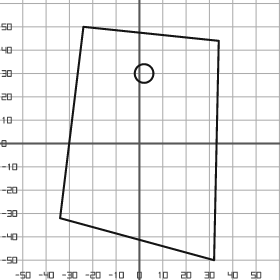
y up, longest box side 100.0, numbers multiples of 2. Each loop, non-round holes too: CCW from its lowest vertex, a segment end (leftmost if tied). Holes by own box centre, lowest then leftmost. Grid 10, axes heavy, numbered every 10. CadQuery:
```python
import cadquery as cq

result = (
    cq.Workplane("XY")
    .moveTo(32.0, -50.0)
    .lineTo(34.0, 44.0)
    .lineTo(-24.0, 50.0)
    .lineTo(-34.0, -32.0)
    .close()
    .moveTo(2.0, 30.0)
    .circle(4.0)
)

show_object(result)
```